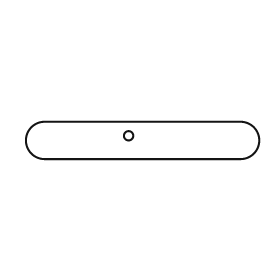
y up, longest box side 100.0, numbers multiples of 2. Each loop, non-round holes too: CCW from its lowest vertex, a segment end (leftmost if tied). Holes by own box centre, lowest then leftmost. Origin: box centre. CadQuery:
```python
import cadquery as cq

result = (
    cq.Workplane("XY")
    .moveTo(-42.0, -8.0)
    .lineTo(42.0, -8.0)
    .threePointArc((50.0, 0.0), (42.0, 8.0))
    .lineTo(-42.0, 8.0)
    .threePointArc((-50.0, 0.0), (-42.0, -8.0))
    .close()
    .moveTo(-6.0, 2.0)
    .circle(2.0)
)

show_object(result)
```